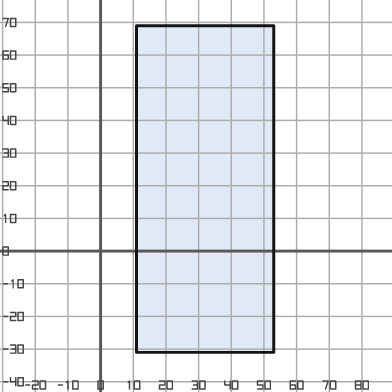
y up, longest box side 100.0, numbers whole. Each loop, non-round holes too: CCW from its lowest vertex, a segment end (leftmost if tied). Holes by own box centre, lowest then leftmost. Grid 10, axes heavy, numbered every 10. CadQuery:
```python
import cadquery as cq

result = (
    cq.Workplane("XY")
    .moveTo(11.0, -31.0)
    .lineTo(53.0, -31.0)
    .lineTo(53.0, 69.0)
    .lineTo(11.0, 69.0)
    .close()
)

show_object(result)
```